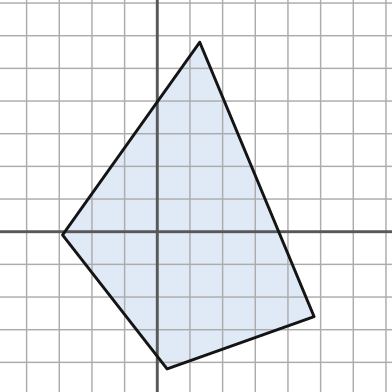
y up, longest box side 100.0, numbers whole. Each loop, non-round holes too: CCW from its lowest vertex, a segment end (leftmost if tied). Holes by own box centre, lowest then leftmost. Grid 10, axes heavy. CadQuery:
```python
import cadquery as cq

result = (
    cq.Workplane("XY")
    .moveTo(3.0, -42.0)
    .lineTo(48.0, -26.0)
    .lineTo(13.0, 58.0)
    .lineTo(-29.0, -1.0)
    .close()
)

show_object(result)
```